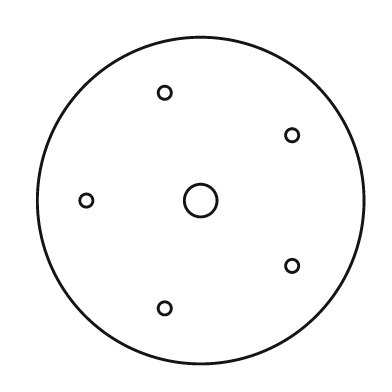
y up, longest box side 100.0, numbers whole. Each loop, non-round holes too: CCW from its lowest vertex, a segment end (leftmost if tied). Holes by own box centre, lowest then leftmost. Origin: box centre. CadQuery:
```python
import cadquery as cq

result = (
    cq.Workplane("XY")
    .moveTo(0.0, 0.0)
    .circle(50.0)
    .moveTo(-11.0, -33.0)
    .circle(2.0)
    .moveTo(28.0, -20.0)
    .circle(2.0)
    .moveTo(-35.0, 0.0)
    .circle(2.0)
    .moveTo(0.0, 0.0)
    .circle(5.0)
    .moveTo(28.0, 20.0)
    .circle(2.0)
    .moveTo(-11.0, 33.0)
    .circle(2.0)
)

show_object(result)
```